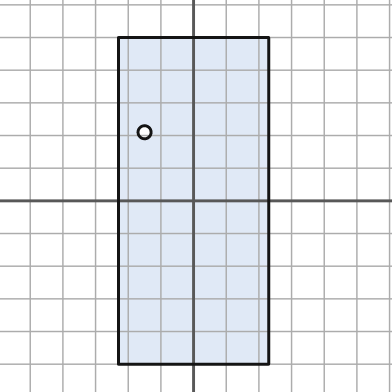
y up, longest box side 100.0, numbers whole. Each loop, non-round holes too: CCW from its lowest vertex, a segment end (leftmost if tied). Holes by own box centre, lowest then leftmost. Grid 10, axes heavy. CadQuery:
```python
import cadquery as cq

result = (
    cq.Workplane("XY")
    .moveTo(-23.0, -50.0)
    .lineTo(23.0, -50.0)
    .lineTo(23.0, 50.0)
    .lineTo(-23.0, 50.0)
    .close()
    .moveTo(-15.0, 21.0)
    .circle(2.0)
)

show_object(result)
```